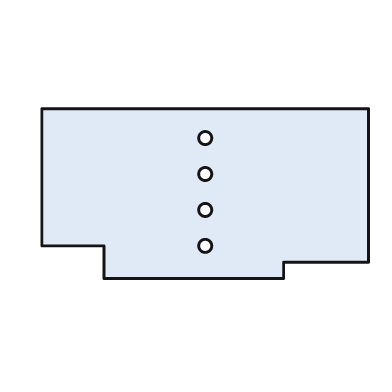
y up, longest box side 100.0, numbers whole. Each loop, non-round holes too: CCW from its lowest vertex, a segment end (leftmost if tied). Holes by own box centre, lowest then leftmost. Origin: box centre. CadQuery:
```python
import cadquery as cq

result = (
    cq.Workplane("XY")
    .moveTo(-31.0, -26.0)
    .lineTo(24.0, -26.0)
    .lineTo(24.0, -21.0)
    .lineTo(50.0, -21.0)
    .lineTo(50.0, 26.0)
    .lineTo(-50.0, 26.0)
    .lineTo(-50.0, -16.0)
    .lineTo(-31.0, -16.0)
    .close()
    .moveTo(0.0, -16.0)
    .circle(2.0)
    .moveTo(0.0, -5.0)
    .circle(2.0)
    .moveTo(0.0, 6.0)
    .circle(2.0)
    .moveTo(0.0, 17.0)
    .circle(2.0)
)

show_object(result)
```